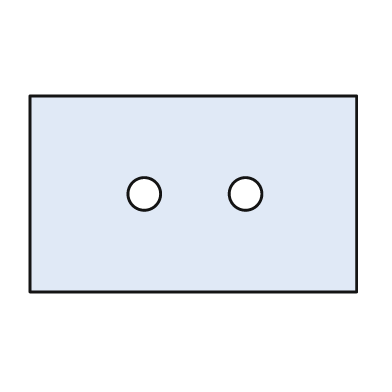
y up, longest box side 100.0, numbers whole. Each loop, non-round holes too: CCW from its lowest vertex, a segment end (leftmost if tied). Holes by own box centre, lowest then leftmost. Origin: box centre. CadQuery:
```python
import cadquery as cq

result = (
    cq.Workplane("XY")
    .moveTo(-50.0, -30.0)
    .lineTo(50.0, -30.0)
    .lineTo(50.0, 30.0)
    .lineTo(-50.0, 30.0)
    .close()
    .moveTo(-15.0, 0.0)
    .circle(5.0)
    .moveTo(16.0, 0.0)
    .circle(5.0)
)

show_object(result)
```